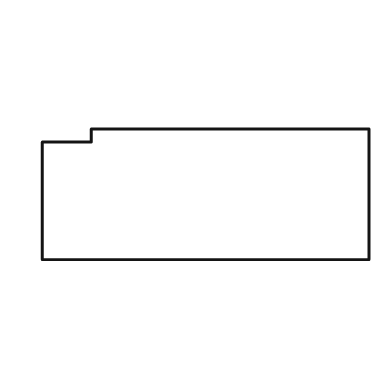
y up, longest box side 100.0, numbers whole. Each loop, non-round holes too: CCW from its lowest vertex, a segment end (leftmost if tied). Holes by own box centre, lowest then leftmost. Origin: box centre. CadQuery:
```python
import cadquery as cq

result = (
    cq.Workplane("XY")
    .moveTo(-50.0, -20.0)
    .lineTo(50.0, -20.0)
    .lineTo(50.0, 20.0)
    .lineTo(-35.0, 20.0)
    .lineTo(-35.0, 16.0)
    .lineTo(-50.0, 16.0)
    .close()
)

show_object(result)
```